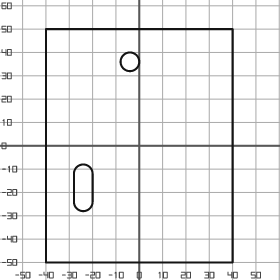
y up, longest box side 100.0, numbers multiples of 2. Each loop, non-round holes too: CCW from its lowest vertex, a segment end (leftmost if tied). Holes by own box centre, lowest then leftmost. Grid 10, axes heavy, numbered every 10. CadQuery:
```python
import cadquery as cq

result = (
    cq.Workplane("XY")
    .moveTo(-40.0, -50.0)
    .lineTo(40.0, -50.0)
    .lineTo(40.0, 50.0)
    .lineTo(-40.0, 50.0)
    .close()
    .moveTo(-28.0, -24.0)
    .threePointArc((-24.0, -28.0), (-20.0, -24.0))
    .lineTo(-20.0, -12.0)
    .threePointArc((-24.0, -8.0), (-28.0, -12.0))
    .close()
    .moveTo(-4.0, 36.0)
    .circle(4.0)
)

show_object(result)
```